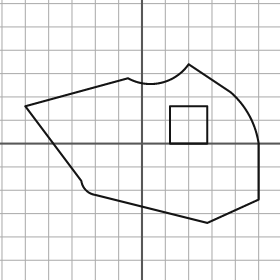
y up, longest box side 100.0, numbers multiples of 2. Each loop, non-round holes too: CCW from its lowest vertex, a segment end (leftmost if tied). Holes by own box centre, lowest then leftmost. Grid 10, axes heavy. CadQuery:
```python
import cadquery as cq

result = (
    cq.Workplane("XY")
    .moveTo(28.0, -34.0)
    .lineTo(50.0, -24.0)
    .lineTo(50.0, 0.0)
    .threePointArc((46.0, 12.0), (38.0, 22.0))
    .lineTo(20.0, 34.0)
    .threePointArc((8.0, 26.0), (-6.0, 28.0))
    .lineTo(-50.0, 16.0)
    .lineTo(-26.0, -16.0)
    .threePointArc((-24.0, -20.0), (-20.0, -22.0))
    .close()
    .moveTo(12.0, 0.0)
    .lineTo(28.0, 0.0)
    .lineTo(28.0, 16.0)
    .lineTo(12.0, 16.0)
    .close()
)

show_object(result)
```